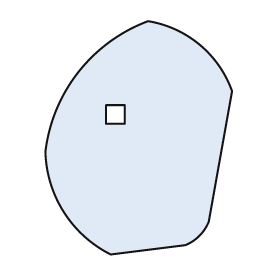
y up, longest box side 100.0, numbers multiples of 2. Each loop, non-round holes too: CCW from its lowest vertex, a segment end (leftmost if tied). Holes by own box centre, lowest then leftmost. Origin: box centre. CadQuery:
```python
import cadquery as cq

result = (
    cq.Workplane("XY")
    .moveTo(-12.0, -50.0)
    .lineTo(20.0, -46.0)
    .threePointArc((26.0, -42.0), (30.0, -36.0))
    .lineTo(40.0, 20.0)
    .threePointArc((26.0, 40.0), (4.0, 50.0))
    .threePointArc((-26.0, 28.0), (-40.0, -6.0))
    .threePointArc((-32.0, -32.0), (-12.0, -50.0))
    .close()
    .moveTo(-14.0, 6.0)
    .lineTo(-6.0, 6.0)
    .lineTo(-6.0, 14.0)
    .lineTo(-14.0, 14.0)
    .close()
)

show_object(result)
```